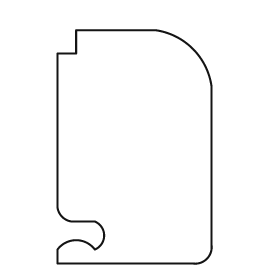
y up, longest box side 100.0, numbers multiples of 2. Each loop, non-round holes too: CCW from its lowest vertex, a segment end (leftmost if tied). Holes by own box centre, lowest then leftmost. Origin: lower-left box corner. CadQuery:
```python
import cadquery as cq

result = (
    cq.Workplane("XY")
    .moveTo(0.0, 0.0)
    .lineTo(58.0, 0.0)
    .threePointArc((64.0, 2.0), (66.0, 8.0))
    .lineTo(66.0, 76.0)
    .threePointArc((58.0, 92.0), (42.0, 100.0))
    .lineTo(8.0, 100.0)
    .lineTo(8.0, 90.0)
    .lineTo(0.0, 90.0)
    .lineTo(0.0, 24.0)
    .threePointArc((2.0, 20.0), (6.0, 18.0))
    .lineTo(16.0, 18.0)
    .threePointArc((20.0, 12.0), (16.0, 6.0))
    .threePointArc((8.0, 10.0), (0.0, 6.0))
    .close()
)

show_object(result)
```